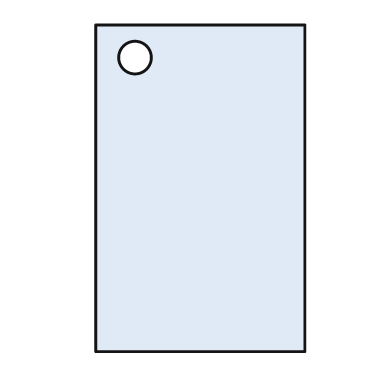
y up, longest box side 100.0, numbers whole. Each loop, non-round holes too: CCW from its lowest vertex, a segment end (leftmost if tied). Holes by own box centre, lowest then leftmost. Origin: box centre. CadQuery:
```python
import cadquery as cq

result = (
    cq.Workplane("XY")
    .moveTo(-32.0, -50.0)
    .lineTo(32.0, -50.0)
    .lineTo(32.0, 50.0)
    .lineTo(-32.0, 50.0)
    .close()
    .moveTo(-20.0, 40.0)
    .circle(5.0)
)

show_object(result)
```